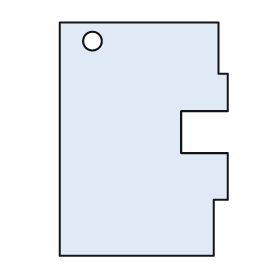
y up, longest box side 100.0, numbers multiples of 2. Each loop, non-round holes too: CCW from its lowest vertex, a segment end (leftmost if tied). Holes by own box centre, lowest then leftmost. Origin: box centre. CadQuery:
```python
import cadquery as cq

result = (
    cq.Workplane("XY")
    .moveTo(-36.0, -50.0)
    .lineTo(30.0, -50.0)
    .lineTo(30.0, -26.0)
    .lineTo(36.0, -26.0)
    .lineTo(36.0, -6.0)
    .lineTo(16.0, -6.0)
    .lineTo(16.0, 12.0)
    .lineTo(36.0, 12.0)
    .lineTo(36.0, 28.0)
    .lineTo(32.0, 28.0)
    .lineTo(32.0, 50.0)
    .lineTo(-36.0, 50.0)
    .close()
    .moveTo(-22.0, 42.0)
    .circle(4.0)
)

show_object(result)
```